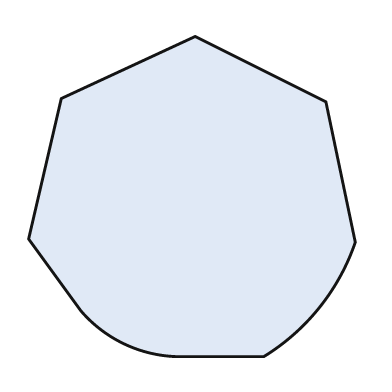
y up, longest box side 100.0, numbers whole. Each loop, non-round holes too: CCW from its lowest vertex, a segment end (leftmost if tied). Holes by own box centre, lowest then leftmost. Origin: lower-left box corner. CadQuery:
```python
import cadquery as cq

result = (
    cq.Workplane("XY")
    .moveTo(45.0, 0.0)
    .lineTo(72.0, 0.0)
    .threePointArc((89.0, 15.0), (100.0, 35.0))
    .lineTo(91.0, 78.0)
    .lineTo(51.0, 98.0)
    .lineTo(10.0, 79.0)
    .lineTo(0.0, 36.0)
    .lineTo(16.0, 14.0)
    .threePointArc((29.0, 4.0), (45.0, 0.0))
    .close()
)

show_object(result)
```